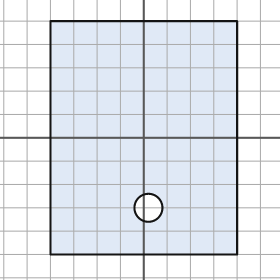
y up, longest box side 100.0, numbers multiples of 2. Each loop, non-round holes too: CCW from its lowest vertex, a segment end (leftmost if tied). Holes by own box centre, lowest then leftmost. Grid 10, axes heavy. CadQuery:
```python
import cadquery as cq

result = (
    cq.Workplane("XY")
    .moveTo(-40.0, -50.0)
    .lineTo(40.0, -50.0)
    .lineTo(40.0, 50.0)
    .lineTo(-40.0, 50.0)
    .close()
    .moveTo(2.0, -30.0)
    .circle(6.0)
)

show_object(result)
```